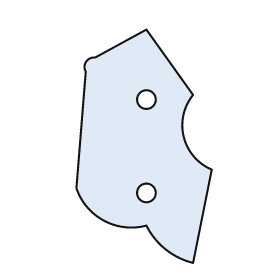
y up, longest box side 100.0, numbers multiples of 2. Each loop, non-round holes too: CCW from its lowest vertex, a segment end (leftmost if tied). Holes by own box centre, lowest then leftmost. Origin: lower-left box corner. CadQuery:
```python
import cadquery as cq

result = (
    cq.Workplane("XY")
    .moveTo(50.0, 0.0)
    .lineTo(58.0, 40.0)
    .threePointArc((46.0, 54.0), (50.0, 72.0))
    .lineTo(30.0, 100.0)
    .lineTo(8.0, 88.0)
    .threePointArc((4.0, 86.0), (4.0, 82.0))
    .lineTo(0.0, 32.0)
    .threePointArc((12.0, 18.0), (30.0, 16.0))
    .threePointArc((38.0, 6.0), (50.0, 0.0))
    .close()
    .moveTo(30.0, 30.0)
    .circle(4.0)
    .moveTo(30.0, 70.0)
    .circle(4.0)
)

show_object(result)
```